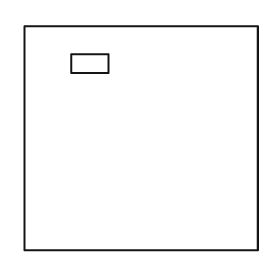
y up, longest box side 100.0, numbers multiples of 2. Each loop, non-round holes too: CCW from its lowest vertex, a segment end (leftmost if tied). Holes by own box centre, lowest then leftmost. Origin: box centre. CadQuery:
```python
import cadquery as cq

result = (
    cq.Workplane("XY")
    .moveTo(-50.0, -48.0)
    .lineTo(50.0, -48.0)
    .lineTo(50.0, 48.0)
    .lineTo(-50.0, 48.0)
    .close()
    .moveTo(-30.0, 28.0)
    .lineTo(-14.0, 28.0)
    .lineTo(-14.0, 36.0)
    .lineTo(-30.0, 36.0)
    .close()
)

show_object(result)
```